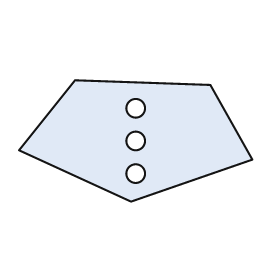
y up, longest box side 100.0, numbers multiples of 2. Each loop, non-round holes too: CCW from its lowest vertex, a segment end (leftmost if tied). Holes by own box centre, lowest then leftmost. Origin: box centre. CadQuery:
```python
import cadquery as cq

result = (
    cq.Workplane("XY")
    .moveTo(-2.0, -26.0)
    .lineTo(50.0, -8.0)
    .lineTo(32.0, 24.0)
    .lineTo(-26.0, 26.0)
    .lineTo(-50.0, -4.0)
    .close()
    .moveTo(0.0, -14.0)
    .circle(4.0)
    .moveTo(0.0, 0.0)
    .circle(4.0)
    .moveTo(0.0, 14.0)
    .circle(4.0)
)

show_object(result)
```